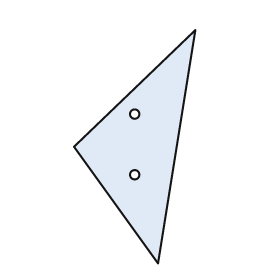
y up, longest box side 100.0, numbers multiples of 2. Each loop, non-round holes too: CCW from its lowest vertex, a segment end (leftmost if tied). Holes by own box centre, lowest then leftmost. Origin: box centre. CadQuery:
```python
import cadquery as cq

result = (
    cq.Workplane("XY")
    .moveTo(10.0, -50.0)
    .lineTo(26.0, 50.0)
    .lineTo(-26.0, 0.0)
    .close()
    .moveTo(0.0, -12.0)
    .circle(2.0)
    .moveTo(0.0, 14.0)
    .circle(2.0)
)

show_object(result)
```